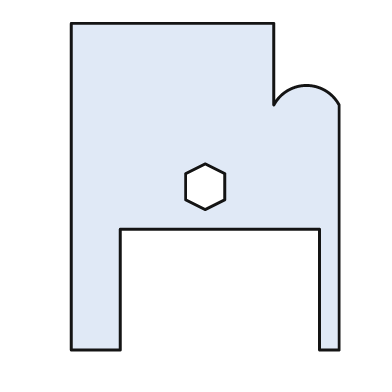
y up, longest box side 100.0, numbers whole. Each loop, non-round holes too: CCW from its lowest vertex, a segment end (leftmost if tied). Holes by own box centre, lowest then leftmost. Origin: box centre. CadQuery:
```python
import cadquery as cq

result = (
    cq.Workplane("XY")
    .moveTo(-41.0, -50.0)
    .lineTo(-26.0, -50.0)
    .lineTo(-26.0, -13.0)
    .lineTo(35.0, -13.0)
    .lineTo(35.0, -50.0)
    .lineTo(41.0, -50.0)
    .lineTo(41.0, 25.0)
    .threePointArc((31.0, 31.0), (21.0, 25.0))
    .lineTo(21.0, 50.0)
    .lineTo(-41.0, 50.0)
    .close()
    .moveTo(0.0, -7.0)
    .lineTo(6.0, -4.0)
    .lineTo(6.0, 4.0)
    .lineTo(0.0, 7.0)
    .lineTo(-6.0, 4.0)
    .lineTo(-6.0, -4.0)
    .close()
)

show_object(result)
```